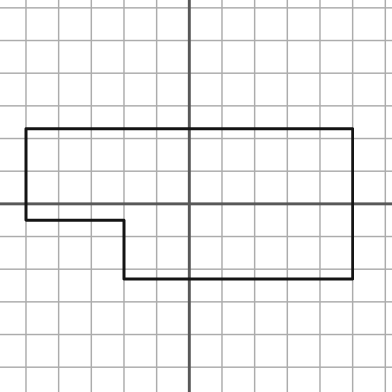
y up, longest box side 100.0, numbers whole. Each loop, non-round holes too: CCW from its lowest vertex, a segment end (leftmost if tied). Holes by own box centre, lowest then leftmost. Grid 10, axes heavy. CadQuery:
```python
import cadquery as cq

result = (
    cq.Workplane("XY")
    .moveTo(-20.0, -23.0)
    .lineTo(50.0, -23.0)
    .lineTo(50.0, 23.0)
    .lineTo(-50.0, 23.0)
    .lineTo(-50.0, -5.0)
    .lineTo(-20.0, -5.0)
    .close()
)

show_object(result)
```